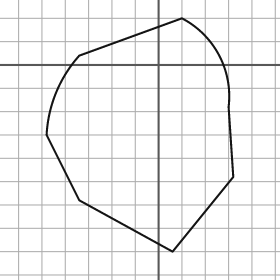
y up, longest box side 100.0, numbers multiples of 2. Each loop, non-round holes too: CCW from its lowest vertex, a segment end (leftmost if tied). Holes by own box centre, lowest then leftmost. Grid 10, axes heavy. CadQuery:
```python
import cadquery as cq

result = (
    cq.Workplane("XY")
    .moveTo(6.0, -80.0)
    .lineTo(32.0, -48.0)
    .lineTo(30.0, -18.0)
    .threePointArc((26.0, 4.0), (10.0, 20.0))
    .lineTo(-34.0, 4.0)
    .threePointArc((-44.0, -12.0), (-48.0, -30.0))
    .lineTo(-34.0, -58.0)
    .close()
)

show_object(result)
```